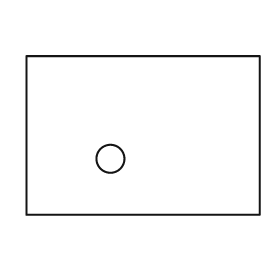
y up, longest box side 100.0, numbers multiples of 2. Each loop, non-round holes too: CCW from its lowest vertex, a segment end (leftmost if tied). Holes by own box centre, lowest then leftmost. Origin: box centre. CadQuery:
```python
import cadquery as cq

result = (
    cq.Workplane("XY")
    .moveTo(-50.0, -34.0)
    .lineTo(50.0, -34.0)
    .lineTo(50.0, 34.0)
    .lineTo(-50.0, 34.0)
    .close()
    .moveTo(-14.0, -10.0)
    .circle(6.0)
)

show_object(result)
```